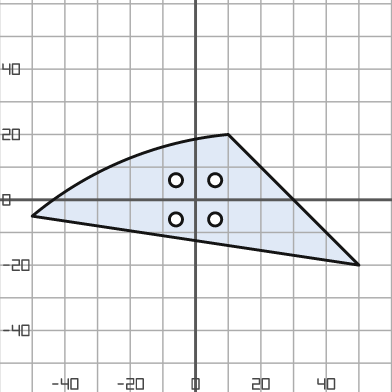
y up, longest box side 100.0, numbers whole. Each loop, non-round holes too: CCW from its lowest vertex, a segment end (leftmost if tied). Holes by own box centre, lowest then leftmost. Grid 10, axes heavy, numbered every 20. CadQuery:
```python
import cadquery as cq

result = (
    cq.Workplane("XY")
    .moveTo(50.0, -20.0)
    .lineTo(10.0, 20.0)
    .threePointArc((-22.0, 12.0), (-50.0, -5.0))
    .close()
    .moveTo(-6.0, -6.0)
    .circle(2.0)
    .moveTo(6.0, -6.0)
    .circle(2.0)
    .moveTo(-6.0, 6.0)
    .circle(2.0)
    .moveTo(6.0, 6.0)
    .circle(2.0)
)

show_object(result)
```